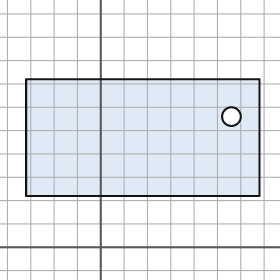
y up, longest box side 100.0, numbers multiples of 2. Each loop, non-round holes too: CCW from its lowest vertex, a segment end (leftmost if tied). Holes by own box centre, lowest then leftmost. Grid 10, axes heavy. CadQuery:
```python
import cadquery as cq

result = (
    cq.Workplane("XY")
    .moveTo(-32.0, 22.0)
    .lineTo(68.0, 22.0)
    .lineTo(68.0, 72.0)
    .lineTo(-32.0, 72.0)
    .close()
    .moveTo(56.0, 56.0)
    .circle(4.0)
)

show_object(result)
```